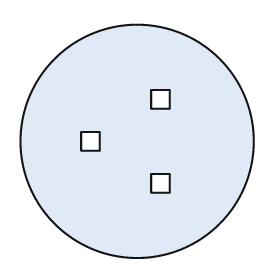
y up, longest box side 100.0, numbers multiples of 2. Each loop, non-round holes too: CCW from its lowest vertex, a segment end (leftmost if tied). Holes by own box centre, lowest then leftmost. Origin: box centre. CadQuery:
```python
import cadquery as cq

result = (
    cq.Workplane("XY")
    .moveTo(0.0, 0.0)
    .circle(50.0)
    .moveTo(6.0, -22.0)
    .lineTo(14.0, -22.0)
    .lineTo(14.0, -14.0)
    .lineTo(6.0, -14.0)
    .close()
    .moveTo(-24.0, -4.0)
    .lineTo(-16.0, -4.0)
    .lineTo(-16.0, 4.0)
    .lineTo(-24.0, 4.0)
    .close()
    .moveTo(6.0, 14.0)
    .lineTo(14.0, 14.0)
    .lineTo(14.0, 22.0)
    .lineTo(6.0, 22.0)
    .close()
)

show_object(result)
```